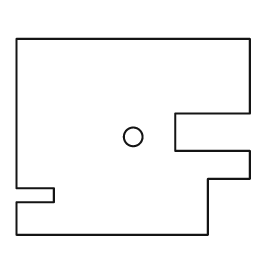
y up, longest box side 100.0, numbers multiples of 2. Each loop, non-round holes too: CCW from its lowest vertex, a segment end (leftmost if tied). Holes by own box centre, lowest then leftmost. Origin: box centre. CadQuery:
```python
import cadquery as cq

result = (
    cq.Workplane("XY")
    .moveTo(-50.0, -42.0)
    .lineTo(32.0, -42.0)
    .lineTo(32.0, -18.0)
    .lineTo(50.0, -18.0)
    .lineTo(50.0, -6.0)
    .lineTo(18.0, -6.0)
    .lineTo(18.0, 10.0)
    .lineTo(50.0, 10.0)
    .lineTo(50.0, 42.0)
    .lineTo(-50.0, 42.0)
    .lineTo(-50.0, -22.0)
    .lineTo(-34.0, -22.0)
    .lineTo(-34.0, -28.0)
    .lineTo(-50.0, -28.0)
    .close()
    .moveTo(0.0, 0.0)
    .circle(4.0)
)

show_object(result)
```